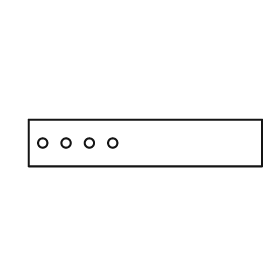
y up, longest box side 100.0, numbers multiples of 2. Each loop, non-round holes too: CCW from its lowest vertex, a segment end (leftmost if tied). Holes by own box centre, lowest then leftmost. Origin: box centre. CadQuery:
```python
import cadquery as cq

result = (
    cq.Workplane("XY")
    .moveTo(-50.0, -10.0)
    .lineTo(50.0, -10.0)
    .lineTo(50.0, 10.0)
    .lineTo(-50.0, 10.0)
    .close()
    .moveTo(-44.0, 0.0)
    .circle(2.0)
    .moveTo(-34.0, 0.0)
    .circle(2.0)
    .moveTo(-24.0, 0.0)
    .circle(2.0)
    .moveTo(-14.0, 0.0)
    .circle(2.0)
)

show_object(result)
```